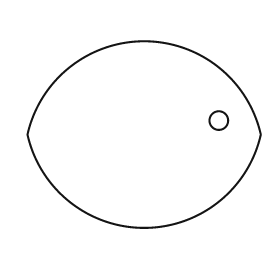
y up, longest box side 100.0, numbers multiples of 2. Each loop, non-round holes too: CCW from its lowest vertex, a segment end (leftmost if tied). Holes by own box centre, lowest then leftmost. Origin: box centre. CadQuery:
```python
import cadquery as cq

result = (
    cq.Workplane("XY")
    .moveTo(-50.0, 0.0)
    .threePointArc((0.0, -40.0), (50.0, 0.0))
    .threePointArc((0.0, 40.0), (-50.0, 0.0))
    .close()
    .moveTo(32.0, 6.0)
    .circle(4.0)
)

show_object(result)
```